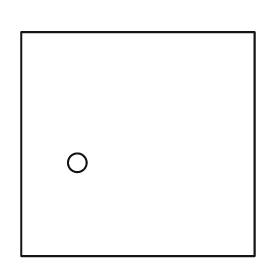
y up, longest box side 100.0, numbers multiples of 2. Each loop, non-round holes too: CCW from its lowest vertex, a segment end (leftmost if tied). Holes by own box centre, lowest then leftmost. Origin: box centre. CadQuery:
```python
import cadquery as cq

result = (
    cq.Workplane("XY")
    .moveTo(-50.0, -48.0)
    .lineTo(50.0, -48.0)
    .lineTo(50.0, 48.0)
    .lineTo(-50.0, 48.0)
    .close()
    .moveTo(-26.0, -8.0)
    .circle(4.0)
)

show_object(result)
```